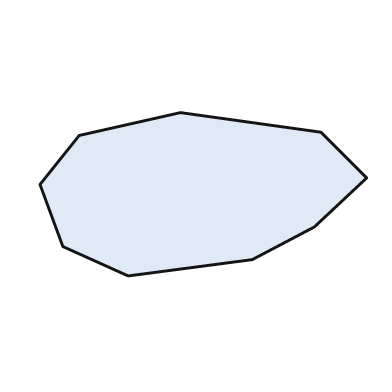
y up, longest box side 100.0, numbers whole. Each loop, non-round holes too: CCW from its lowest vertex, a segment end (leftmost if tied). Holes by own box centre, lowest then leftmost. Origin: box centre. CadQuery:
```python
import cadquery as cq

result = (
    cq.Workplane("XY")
    .moveTo(-23.0, -25.0)
    .lineTo(15.0, -20.0)
    .lineTo(34.0, -10.0)
    .lineTo(50.0, 5.0)
    .lineTo(36.0, 19.0)
    .lineTo(-7.0, 25.0)
    .lineTo(-38.0, 18.0)
    .lineTo(-50.0, 3.0)
    .lineTo(-43.0, -16.0)
    .close()
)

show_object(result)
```